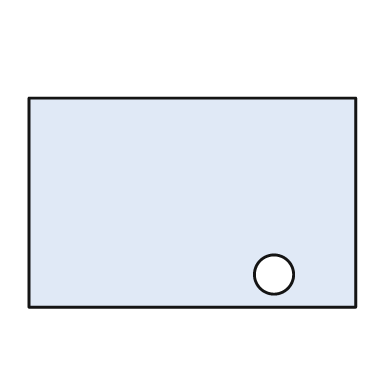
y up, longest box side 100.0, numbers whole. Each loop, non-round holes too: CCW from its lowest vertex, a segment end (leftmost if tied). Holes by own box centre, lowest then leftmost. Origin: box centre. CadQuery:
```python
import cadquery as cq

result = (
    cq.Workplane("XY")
    .moveTo(-50.0, -32.0)
    .lineTo(50.0, -32.0)
    .lineTo(50.0, 32.0)
    .lineTo(-50.0, 32.0)
    .close()
    .moveTo(25.0, -22.0)
    .circle(6.0)
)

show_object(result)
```